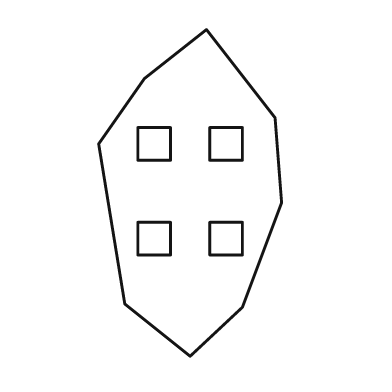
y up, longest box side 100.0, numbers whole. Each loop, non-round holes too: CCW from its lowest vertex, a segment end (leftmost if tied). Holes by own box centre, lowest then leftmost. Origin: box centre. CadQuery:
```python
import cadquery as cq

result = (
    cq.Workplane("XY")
    .moveTo(0.0, -50.0)
    .lineTo(16.0, -35.0)
    .lineTo(28.0, -3.0)
    .lineTo(26.0, 23.0)
    .lineTo(5.0, 50.0)
    .lineTo(-14.0, 35.0)
    .lineTo(-28.0, 15.0)
    .lineTo(-20.0, -34.0)
    .close()
    .moveTo(-16.0, -19.0)
    .lineTo(-6.0, -19.0)
    .lineTo(-6.0, -9.0)
    .lineTo(-16.0, -9.0)
    .close()
    .moveTo(6.0, -19.0)
    .lineTo(16.0, -19.0)
    .lineTo(16.0, -9.0)
    .lineTo(6.0, -9.0)
    .close()
    .moveTo(-16.0, 10.0)
    .lineTo(-6.0, 10.0)
    .lineTo(-6.0, 20.0)
    .lineTo(-16.0, 20.0)
    .close()
    .moveTo(6.0, 10.0)
    .lineTo(16.0, 10.0)
    .lineTo(16.0, 20.0)
    .lineTo(6.0, 20.0)
    .close()
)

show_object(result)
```